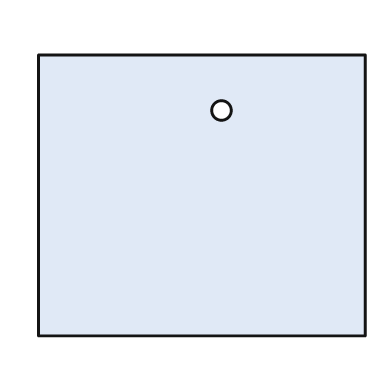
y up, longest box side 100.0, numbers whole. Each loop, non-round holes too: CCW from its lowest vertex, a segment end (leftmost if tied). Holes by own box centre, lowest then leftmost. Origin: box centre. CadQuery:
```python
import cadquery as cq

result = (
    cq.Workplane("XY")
    .moveTo(-50.0, -43.0)
    .lineTo(50.0, -43.0)
    .lineTo(50.0, 43.0)
    .lineTo(-50.0, 43.0)
    .close()
    .moveTo(6.0, 26.0)
    .circle(3.0)
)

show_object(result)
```